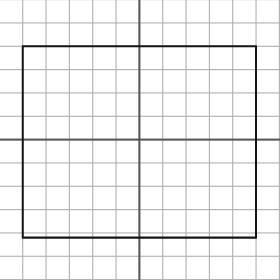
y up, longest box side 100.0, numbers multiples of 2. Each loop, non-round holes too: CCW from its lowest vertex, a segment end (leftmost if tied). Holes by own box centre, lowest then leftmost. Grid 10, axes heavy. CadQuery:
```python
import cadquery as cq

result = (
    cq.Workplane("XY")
    .moveTo(-50.0, -42.0)
    .lineTo(50.0, -42.0)
    .lineTo(50.0, 40.0)
    .lineTo(-50.0, 40.0)
    .close()
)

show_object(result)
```